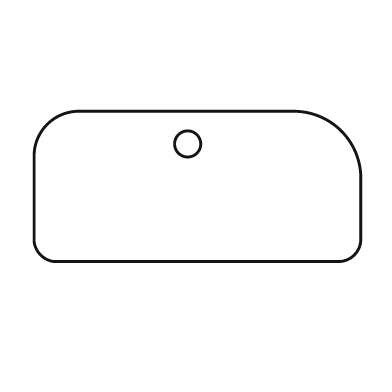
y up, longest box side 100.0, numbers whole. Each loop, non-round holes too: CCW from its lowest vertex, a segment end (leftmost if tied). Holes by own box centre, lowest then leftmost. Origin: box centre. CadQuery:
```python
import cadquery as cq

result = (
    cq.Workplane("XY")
    .moveTo(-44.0, -23.0)
    .lineTo(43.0, -23.0)
    .threePointArc((48.0, -21.0), (50.0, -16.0))
    .lineTo(50.0, 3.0)
    .threePointArc((44.0, 17.0), (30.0, 23.0))
    .lineTo(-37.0, 23.0)
    .threePointArc((-46.0, 19.0), (-50.0, 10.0))
    .lineTo(-50.0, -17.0)
    .threePointArc((-48.0, -21.0), (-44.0, -23.0))
    .close()
    .moveTo(-3.0, 13.0)
    .circle(4.0)
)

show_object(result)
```